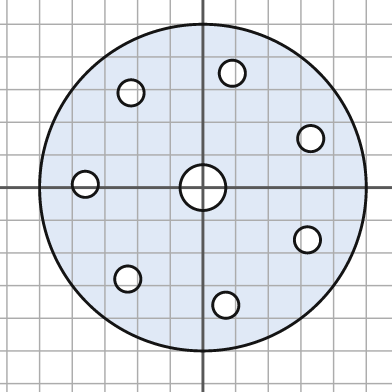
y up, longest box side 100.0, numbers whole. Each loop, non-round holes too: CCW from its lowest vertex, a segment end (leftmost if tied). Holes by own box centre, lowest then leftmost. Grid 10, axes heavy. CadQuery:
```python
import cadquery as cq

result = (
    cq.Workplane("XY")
    .moveTo(0.0, 0.0)
    .circle(50.0)
    .moveTo(7.0, -36.0)
    .circle(4.0)
    .moveTo(-23.0, -28.0)
    .circle(4.0)
    .moveTo(32.0, -16.0)
    .circle(4.0)
    .moveTo(0.0, 0.0)
    .circle(7.0)
    .moveTo(-36.0, 1.0)
    .circle(4.0)
    .moveTo(33.0, 15.0)
    .circle(4.0)
    .moveTo(-22.0, 29.0)
    .circle(4.0)
    .moveTo(9.0, 35.0)
    .circle(4.0)
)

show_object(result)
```